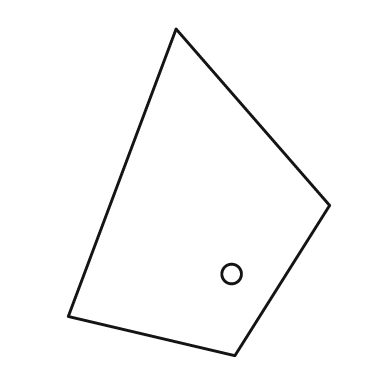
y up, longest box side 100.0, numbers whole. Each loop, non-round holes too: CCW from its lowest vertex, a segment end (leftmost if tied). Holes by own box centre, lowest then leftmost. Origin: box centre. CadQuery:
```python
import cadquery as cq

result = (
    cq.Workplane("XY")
    .moveTo(11.0, -50.0)
    .lineTo(40.0, -4.0)
    .lineTo(-7.0, 50.0)
    .lineTo(-40.0, -38.0)
    .close()
    .moveTo(10.0, -25.0)
    .circle(3.0)
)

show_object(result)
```